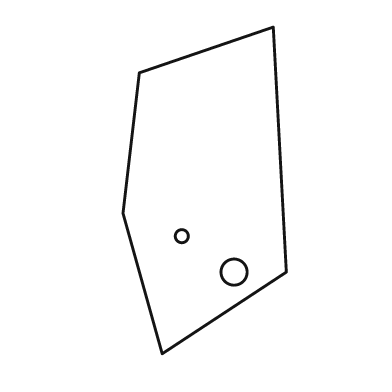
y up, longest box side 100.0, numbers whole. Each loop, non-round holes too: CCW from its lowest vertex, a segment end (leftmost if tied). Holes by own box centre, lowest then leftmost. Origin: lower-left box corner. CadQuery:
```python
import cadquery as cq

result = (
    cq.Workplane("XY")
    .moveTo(12.0, 0.0)
    .lineTo(50.0, 25.0)
    .lineTo(46.0, 100.0)
    .lineTo(5.0, 86.0)
    .lineTo(0.0, 43.0)
    .close()
    .moveTo(34.0, 25.0)
    .circle(4.0)
    .moveTo(18.0, 36.0)
    .circle(2.0)
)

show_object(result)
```